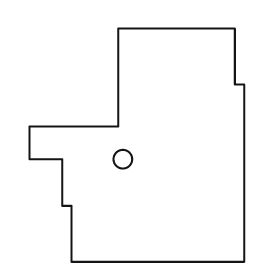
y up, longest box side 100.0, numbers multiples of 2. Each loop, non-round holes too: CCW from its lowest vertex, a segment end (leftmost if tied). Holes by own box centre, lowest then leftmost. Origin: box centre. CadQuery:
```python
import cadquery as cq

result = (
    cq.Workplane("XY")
    .moveTo(-28.0, -50.0)
    .lineTo(46.0, -50.0)
    .lineTo(46.0, 26.0)
    .lineTo(42.0, 26.0)
    .lineTo(42.0, 50.0)
    .lineTo(-8.0, 50.0)
    .lineTo(-8.0, 8.0)
    .lineTo(-46.0, 8.0)
    .lineTo(-46.0, -6.0)
    .lineTo(-32.0, -6.0)
    .lineTo(-32.0, -26.0)
    .lineTo(-28.0, -26.0)
    .close()
    .moveTo(-6.0, -6.0)
    .circle(4.0)
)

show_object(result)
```